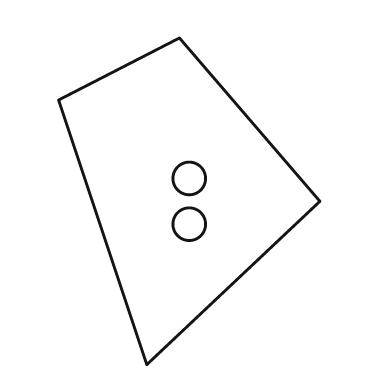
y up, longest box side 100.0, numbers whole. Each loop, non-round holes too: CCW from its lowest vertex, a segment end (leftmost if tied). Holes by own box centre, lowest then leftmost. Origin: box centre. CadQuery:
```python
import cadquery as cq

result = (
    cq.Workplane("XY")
    .moveTo(-13.0, -50.0)
    .lineTo(40.0, 0.0)
    .lineTo(-3.0, 50.0)
    .lineTo(-40.0, 31.0)
    .close()
    .moveTo(0.0, -7.0)
    .circle(5.0)
    .moveTo(0.0, 7.0)
    .circle(5.0)
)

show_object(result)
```